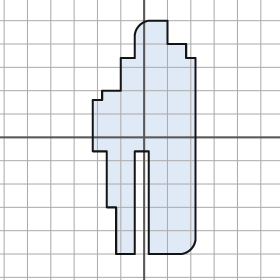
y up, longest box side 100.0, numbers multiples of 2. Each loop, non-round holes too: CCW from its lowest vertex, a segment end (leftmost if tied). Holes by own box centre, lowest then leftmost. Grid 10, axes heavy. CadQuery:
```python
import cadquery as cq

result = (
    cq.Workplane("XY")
    .moveTo(-12.0, -50.0)
    .lineTo(-4.0, -50.0)
    .lineTo(-4.0, -6.0)
    .lineTo(2.0, -6.0)
    .lineTo(2.0, -50.0)
    .lineTo(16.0, -50.0)
    .threePointArc((20.0, -48.0), (22.0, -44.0))
    .lineTo(22.0, 34.0)
    .lineTo(18.0, 34.0)
    .lineTo(18.0, 40.0)
    .lineTo(10.0, 40.0)
    .lineTo(10.0, 50.0)
    .lineTo(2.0, 50.0)
    .threePointArc((-2.0, 48.0), (-4.0, 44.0))
    .lineTo(-4.0, 34.0)
    .lineTo(-10.0, 34.0)
    .lineTo(-10.0, 20.0)
    .lineTo(-18.0, 20.0)
    .lineTo(-18.0, 16.0)
    .lineTo(-22.0, 16.0)
    .lineTo(-22.0, -6.0)
    .lineTo(-16.0, -6.0)
    .lineTo(-16.0, -30.0)
    .lineTo(-12.0, -30.0)
    .close()
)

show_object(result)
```